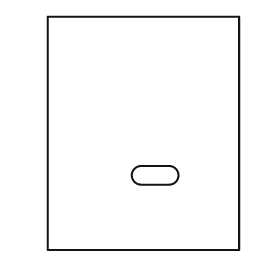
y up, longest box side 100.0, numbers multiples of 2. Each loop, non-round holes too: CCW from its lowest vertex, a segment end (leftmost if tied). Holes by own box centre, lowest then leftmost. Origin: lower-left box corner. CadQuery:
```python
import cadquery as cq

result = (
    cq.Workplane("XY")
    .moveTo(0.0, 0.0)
    .lineTo(82.0, 0.0)
    .lineTo(82.0, 100.0)
    .lineTo(0.0, 100.0)
    .close()
    .moveTo(40.0, 28.0)
    .lineTo(52.0, 28.0)
    .threePointArc((56.0, 32.0), (52.0, 36.0))
    .lineTo(40.0, 36.0)
    .threePointArc((36.0, 32.0), (40.0, 28.0))
    .close()
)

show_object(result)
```